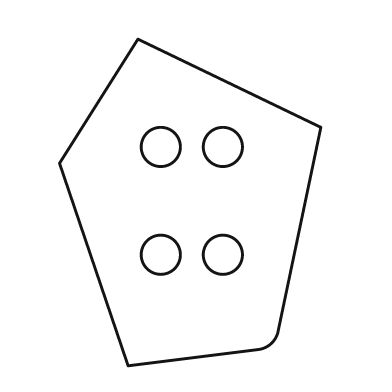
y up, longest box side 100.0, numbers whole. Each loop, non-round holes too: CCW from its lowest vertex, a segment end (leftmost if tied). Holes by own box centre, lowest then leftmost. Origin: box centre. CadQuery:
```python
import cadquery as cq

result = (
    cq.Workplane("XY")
    .moveTo(-19.0, -50.0)
    .lineTo(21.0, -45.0)
    .threePointArc((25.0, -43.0), (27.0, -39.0))
    .lineTo(40.0, 23.0)
    .lineTo(-16.0, 50.0)
    .lineTo(-40.0, 12.0)
    .close()
    .moveTo(-9.0, -16.0)
    .circle(6.0)
    .moveTo(10.0, -16.0)
    .circle(6.0)
    .moveTo(-9.0, 17.0)
    .circle(6.0)
    .moveTo(10.0, 17.0)
    .circle(6.0)
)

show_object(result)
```